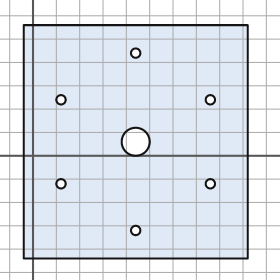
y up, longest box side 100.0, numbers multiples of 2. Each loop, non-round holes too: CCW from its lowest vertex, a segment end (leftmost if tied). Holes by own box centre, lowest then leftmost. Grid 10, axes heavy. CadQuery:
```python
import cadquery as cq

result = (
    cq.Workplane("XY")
    .moveTo(-4.0, -44.0)
    .lineTo(92.0, -44.0)
    .lineTo(92.0, 56.0)
    .lineTo(-4.0, 56.0)
    .close()
    .moveTo(44.0, -32.0)
    .circle(2.0)
    .moveTo(12.0, -12.0)
    .circle(2.0)
    .moveTo(76.0, -12.0)
    .circle(2.0)
    .moveTo(44.0, 6.0)
    .circle(6.0)
    .moveTo(12.0, 24.0)
    .circle(2.0)
    .moveTo(76.0, 24.0)
    .circle(2.0)
    .moveTo(44.0, 44.0)
    .circle(2.0)
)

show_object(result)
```